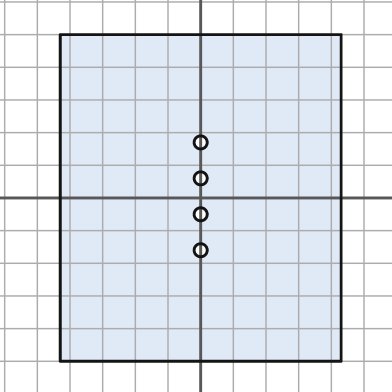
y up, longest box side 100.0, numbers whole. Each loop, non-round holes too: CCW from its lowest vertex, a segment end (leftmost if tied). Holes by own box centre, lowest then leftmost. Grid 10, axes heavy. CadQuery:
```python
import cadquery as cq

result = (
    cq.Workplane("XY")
    .moveTo(-43.0, -50.0)
    .lineTo(43.0, -50.0)
    .lineTo(43.0, 50.0)
    .lineTo(-43.0, 50.0)
    .close()
    .moveTo(0.0, -16.0)
    .circle(2.0)
    .moveTo(0.0, -5.0)
    .circle(2.0)
    .moveTo(0.0, 6.0)
    .circle(2.0)
    .moveTo(0.0, 17.0)
    .circle(2.0)
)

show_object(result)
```